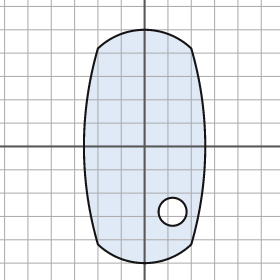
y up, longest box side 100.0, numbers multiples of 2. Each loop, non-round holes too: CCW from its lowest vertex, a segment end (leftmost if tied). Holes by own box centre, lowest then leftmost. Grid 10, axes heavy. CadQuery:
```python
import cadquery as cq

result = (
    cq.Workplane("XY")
    .moveTo(-20.0, -42.0)
    .threePointArc((0.0, -50.0), (20.0, -42.0))
    .threePointArc((26.0, 0.0), (20.0, 42.0))
    .threePointArc((0.0, 50.0), (-20.0, 42.0))
    .threePointArc((-26.0, 0.0), (-20.0, -42.0))
    .close()
    .moveTo(12.0, -28.0)
    .circle(6.0)
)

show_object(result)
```